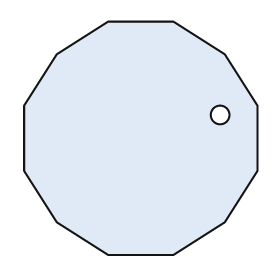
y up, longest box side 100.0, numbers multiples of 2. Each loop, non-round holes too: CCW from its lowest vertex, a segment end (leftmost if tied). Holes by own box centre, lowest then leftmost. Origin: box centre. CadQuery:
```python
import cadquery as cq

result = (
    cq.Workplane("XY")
    .moveTo(-14.0, -50.0)
    .lineTo(14.0, -50.0)
    .lineTo(36.0, -36.0)
    .lineTo(50.0, -14.0)
    .lineTo(50.0, 14.0)
    .lineTo(36.0, 36.0)
    .lineTo(14.0, 50.0)
    .lineTo(-14.0, 50.0)
    .lineTo(-36.0, 36.0)
    .lineTo(-50.0, 14.0)
    .lineTo(-50.0, -14.0)
    .lineTo(-36.0, -36.0)
    .close()
    .moveTo(34.0, 10.0)
    .circle(4.0)
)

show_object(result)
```